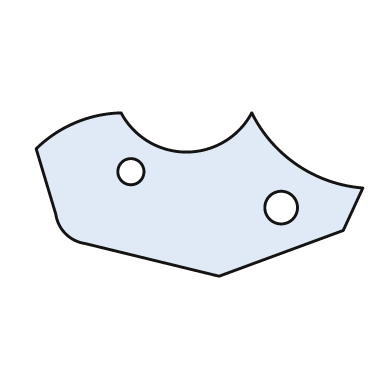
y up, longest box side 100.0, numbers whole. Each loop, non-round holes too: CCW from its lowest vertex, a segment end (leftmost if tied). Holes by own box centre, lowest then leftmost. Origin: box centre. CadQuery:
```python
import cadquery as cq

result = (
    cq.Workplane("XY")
    .moveTo(6.0, -25.0)
    .lineTo(44.0, -11.0)
    .lineTo(50.0, 2.0)
    .threePointArc((30.0, 9.0), (16.0, 25.0))
    .threePointArc((-4.0, 13.0), (-24.0, 25.0))
    .threePointArc((-38.0, 22.0), (-50.0, 14.0))
    .lineTo(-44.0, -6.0)
    .threePointArc((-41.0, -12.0), (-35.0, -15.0))
    .close()
    .moveTo(25.0, -4.0)
    .circle(5.0)
    .moveTo(-21.0, 7.0)
    .circle(4.0)
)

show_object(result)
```